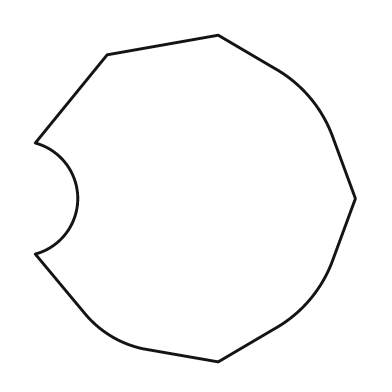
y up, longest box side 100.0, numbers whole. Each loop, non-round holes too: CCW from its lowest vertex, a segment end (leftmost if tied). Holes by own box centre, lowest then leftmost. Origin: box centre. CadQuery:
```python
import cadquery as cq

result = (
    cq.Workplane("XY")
    .moveTo(7.0, -50.0)
    .lineTo(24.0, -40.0)
    .threePointArc((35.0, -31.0), (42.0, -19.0))
    .lineTo(49.0, 0.0)
    .lineTo(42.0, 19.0)
    .threePointArc((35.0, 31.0), (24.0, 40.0))
    .lineTo(7.0, 50.0)
    .lineTo(-27.0, 44.0)
    .lineTo(-49.0, 17.0)
    .threePointArc((-36.0, 0.0), (-49.0, -17.0))
    .lineTo(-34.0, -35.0)
    .threePointArc((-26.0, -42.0), (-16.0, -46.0))
    .close()
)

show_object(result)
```